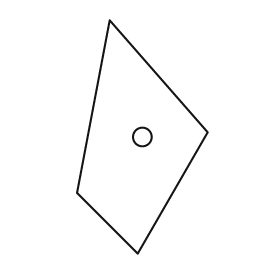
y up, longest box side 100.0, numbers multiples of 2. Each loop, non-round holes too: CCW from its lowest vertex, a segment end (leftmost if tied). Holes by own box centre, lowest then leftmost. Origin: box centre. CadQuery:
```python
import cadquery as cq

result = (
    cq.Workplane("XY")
    .moveTo(-2.0, -50.0)
    .lineTo(28.0, 2.0)
    .lineTo(-14.0, 50.0)
    .lineTo(-28.0, -24.0)
    .close()
    .moveTo(0.0, 0.0)
    .circle(4.0)
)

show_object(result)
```